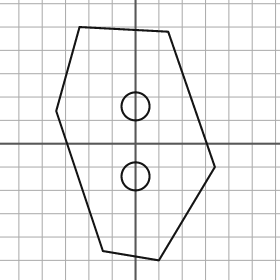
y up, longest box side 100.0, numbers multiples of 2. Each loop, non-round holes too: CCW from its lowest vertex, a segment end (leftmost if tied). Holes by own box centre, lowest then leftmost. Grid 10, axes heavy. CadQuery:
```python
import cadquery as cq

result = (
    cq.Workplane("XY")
    .moveTo(10.0, -50.0)
    .lineTo(34.0, -10.0)
    .lineTo(14.0, 48.0)
    .lineTo(-24.0, 50.0)
    .lineTo(-34.0, 14.0)
    .lineTo(-14.0, -46.0)
    .close()
    .moveTo(0.0, -14.0)
    .circle(6.0)
    .moveTo(0.0, 16.0)
    .circle(6.0)
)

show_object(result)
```